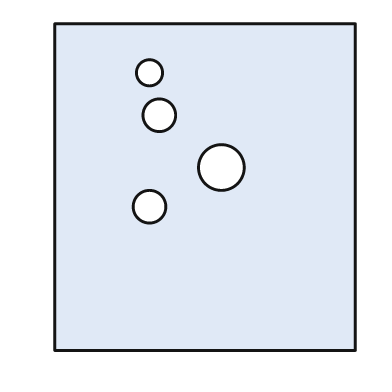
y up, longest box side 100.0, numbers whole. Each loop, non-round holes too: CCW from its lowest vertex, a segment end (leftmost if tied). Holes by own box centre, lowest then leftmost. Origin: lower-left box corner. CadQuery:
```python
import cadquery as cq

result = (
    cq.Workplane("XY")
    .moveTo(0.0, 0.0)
    .lineTo(92.0, 0.0)
    .lineTo(92.0, 100.0)
    .lineTo(0.0, 100.0)
    .close()
    .moveTo(29.0, 44.0)
    .circle(5.0)
    .moveTo(51.0, 56.0)
    .circle(7.0)
    .moveTo(32.0, 72.0)
    .circle(5.0)
    .moveTo(29.0, 85.0)
    .circle(4.0)
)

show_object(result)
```